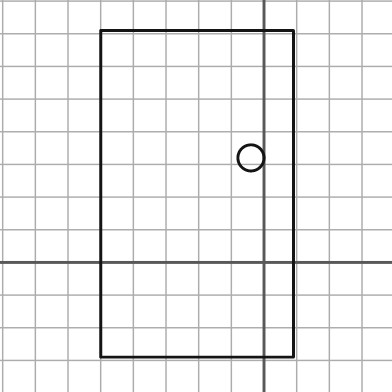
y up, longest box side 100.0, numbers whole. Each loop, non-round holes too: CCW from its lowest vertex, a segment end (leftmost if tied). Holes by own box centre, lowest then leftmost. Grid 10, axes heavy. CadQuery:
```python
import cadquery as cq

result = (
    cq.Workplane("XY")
    .moveTo(-50.0, -29.0)
    .lineTo(9.0, -29.0)
    .lineTo(9.0, 71.0)
    .lineTo(-50.0, 71.0)
    .close()
    .moveTo(-4.0, 32.0)
    .circle(4.0)
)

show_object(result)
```